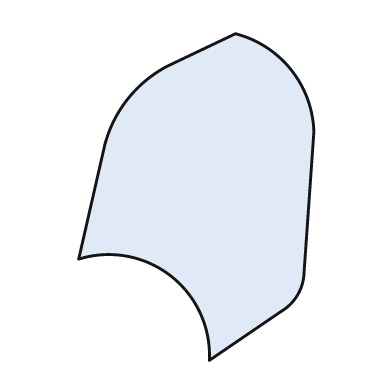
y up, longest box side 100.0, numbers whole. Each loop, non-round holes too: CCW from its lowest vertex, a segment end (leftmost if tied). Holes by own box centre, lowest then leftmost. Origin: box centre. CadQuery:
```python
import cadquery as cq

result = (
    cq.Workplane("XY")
    .moveTo(4.0, -50.0)
    .lineTo(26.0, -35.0)
    .threePointArc((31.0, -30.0), (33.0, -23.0))
    .lineTo(36.0, 20.0)
    .threePointArc((29.0, 39.0), (12.0, 50.0))
    .lineTo(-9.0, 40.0)
    .threePointArc((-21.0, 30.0), (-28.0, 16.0))
    .lineTo(-36.0, -19.0)
    .threePointArc((-8.0, -24.0), (4.0, -50.0))
    .close()
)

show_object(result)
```